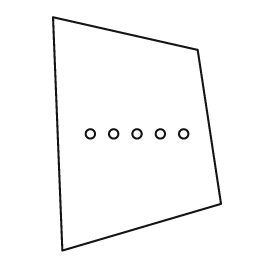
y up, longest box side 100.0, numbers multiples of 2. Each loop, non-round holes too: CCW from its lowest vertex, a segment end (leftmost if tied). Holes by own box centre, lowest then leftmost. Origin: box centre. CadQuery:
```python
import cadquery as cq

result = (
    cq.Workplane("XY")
    .moveTo(-32.0, -50.0)
    .lineTo(36.0, -30.0)
    .lineTo(26.0, 36.0)
    .lineTo(-36.0, 50.0)
    .close()
    .moveTo(-20.0, 0.0)
    .circle(2.0)
    .moveTo(-10.0, 0.0)
    .circle(2.0)
    .moveTo(0.0, 0.0)
    .circle(2.0)
    .moveTo(10.0, 0.0)
    .circle(2.0)
    .moveTo(20.0, 0.0)
    .circle(2.0)
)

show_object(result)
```